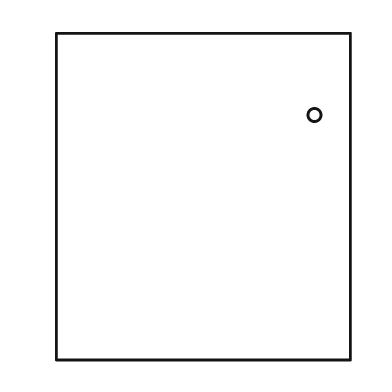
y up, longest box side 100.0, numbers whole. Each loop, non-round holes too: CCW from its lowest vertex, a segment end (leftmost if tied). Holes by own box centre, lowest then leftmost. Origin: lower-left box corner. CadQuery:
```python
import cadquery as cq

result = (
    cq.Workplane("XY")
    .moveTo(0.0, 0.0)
    .lineTo(90.0, 0.0)
    .lineTo(90.0, 100.0)
    .lineTo(0.0, 100.0)
    .close()
    .moveTo(79.0, 75.0)
    .circle(2.0)
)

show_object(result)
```